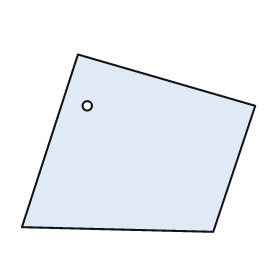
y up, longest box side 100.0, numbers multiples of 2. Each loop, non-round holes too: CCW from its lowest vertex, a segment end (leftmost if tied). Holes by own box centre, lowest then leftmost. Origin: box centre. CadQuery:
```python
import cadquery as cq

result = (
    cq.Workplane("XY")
    .moveTo(32.0, -38.0)
    .lineTo(50.0, 16.0)
    .lineTo(-26.0, 38.0)
    .lineTo(-50.0, -36.0)
    .close()
    .moveTo(-22.0, 16.0)
    .circle(2.0)
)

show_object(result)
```